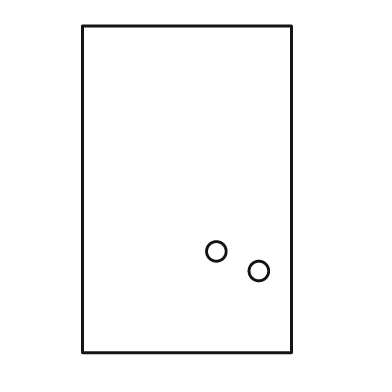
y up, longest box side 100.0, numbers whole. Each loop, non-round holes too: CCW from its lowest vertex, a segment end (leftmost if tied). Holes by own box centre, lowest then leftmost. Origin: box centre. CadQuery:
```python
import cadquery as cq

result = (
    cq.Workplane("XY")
    .moveTo(-32.0, -50.0)
    .lineTo(32.0, -50.0)
    .lineTo(32.0, 50.0)
    .lineTo(-32.0, 50.0)
    .close()
    .moveTo(22.0, -25.0)
    .circle(3.0)
    .moveTo(9.0, -19.0)
    .circle(3.0)
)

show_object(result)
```